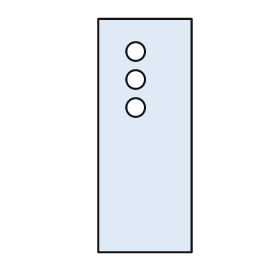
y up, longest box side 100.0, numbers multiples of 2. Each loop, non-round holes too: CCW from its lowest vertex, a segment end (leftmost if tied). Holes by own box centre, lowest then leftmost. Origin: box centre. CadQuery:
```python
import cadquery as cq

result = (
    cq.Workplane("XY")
    .moveTo(-20.0, -50.0)
    .lineTo(20.0, -50.0)
    .lineTo(20.0, 50.0)
    .lineTo(-20.0, 50.0)
    .close()
    .moveTo(-4.0, 12.0)
    .circle(4.0)
    .moveTo(-4.0, 24.0)
    .circle(4.0)
    .moveTo(-4.0, 36.0)
    .circle(4.0)
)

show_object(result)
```